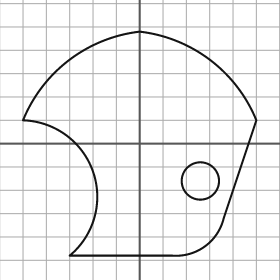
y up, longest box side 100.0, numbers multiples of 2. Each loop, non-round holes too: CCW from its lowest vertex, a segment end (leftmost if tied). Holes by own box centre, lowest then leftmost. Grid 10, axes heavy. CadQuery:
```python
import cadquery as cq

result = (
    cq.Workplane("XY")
    .moveTo(-30.0, -48.0)
    .lineTo(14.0, -48.0)
    .threePointArc((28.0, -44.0), (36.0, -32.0))
    .lineTo(50.0, 10.0)
    .threePointArc((30.0, 36.0), (0.0, 48.0))
    .threePointArc((-30.0, 36.0), (-50.0, 10.0))
    .threePointArc((-20.0, -12.0), (-30.0, -48.0))
    .close()
    .moveTo(26.0, -16.0)
    .circle(8.0)
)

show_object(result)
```